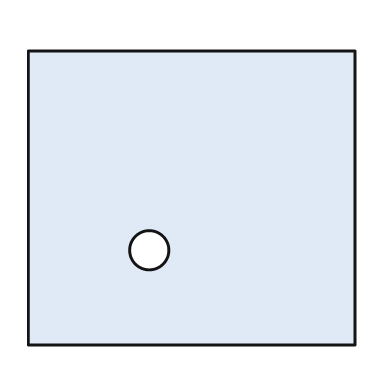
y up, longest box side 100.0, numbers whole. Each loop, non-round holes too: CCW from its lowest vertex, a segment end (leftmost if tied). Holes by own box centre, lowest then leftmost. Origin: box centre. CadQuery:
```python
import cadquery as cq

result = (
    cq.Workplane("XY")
    .moveTo(-50.0, -45.0)
    .lineTo(50.0, -45.0)
    .lineTo(50.0, 45.0)
    .lineTo(-50.0, 45.0)
    .close()
    .moveTo(-13.0, -16.0)
    .circle(6.0)
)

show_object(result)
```